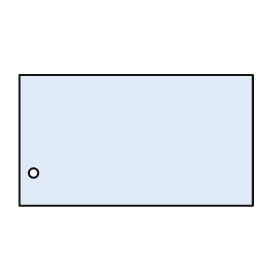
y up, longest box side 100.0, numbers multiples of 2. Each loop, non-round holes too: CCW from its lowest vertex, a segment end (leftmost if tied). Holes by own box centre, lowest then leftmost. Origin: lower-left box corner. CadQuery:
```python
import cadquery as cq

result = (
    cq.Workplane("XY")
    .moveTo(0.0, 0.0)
    .lineTo(100.0, 0.0)
    .lineTo(100.0, 56.0)
    .lineTo(0.0, 56.0)
    .close()
    .moveTo(6.0, 14.0)
    .circle(2.0)
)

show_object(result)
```